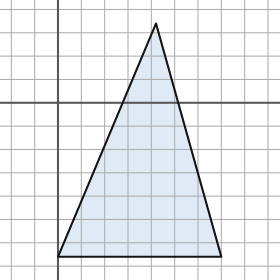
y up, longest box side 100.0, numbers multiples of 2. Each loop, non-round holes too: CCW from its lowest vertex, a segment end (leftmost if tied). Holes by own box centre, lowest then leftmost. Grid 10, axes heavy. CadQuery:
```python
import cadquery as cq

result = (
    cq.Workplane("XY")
    .moveTo(0.0, -66.0)
    .lineTo(70.0, -66.0)
    .lineTo(42.0, 34.0)
    .close()
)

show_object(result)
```